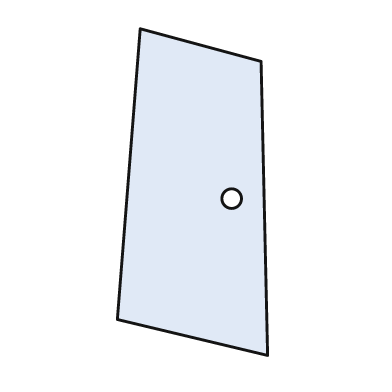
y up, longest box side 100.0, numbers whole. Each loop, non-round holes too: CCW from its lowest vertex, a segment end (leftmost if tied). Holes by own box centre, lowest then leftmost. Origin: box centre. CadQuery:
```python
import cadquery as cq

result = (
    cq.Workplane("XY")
    .moveTo(23.0, -50.0)
    .lineTo(21.0, 40.0)
    .lineTo(-16.0, 50.0)
    .lineTo(-23.0, -39.0)
    .close()
    .moveTo(12.0, -2.0)
    .circle(3.0)
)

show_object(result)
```